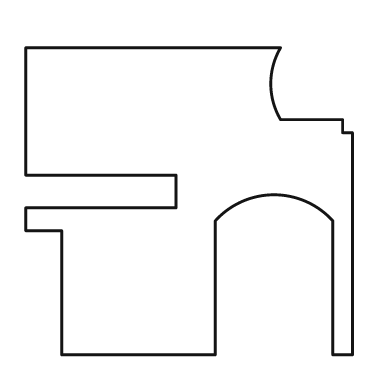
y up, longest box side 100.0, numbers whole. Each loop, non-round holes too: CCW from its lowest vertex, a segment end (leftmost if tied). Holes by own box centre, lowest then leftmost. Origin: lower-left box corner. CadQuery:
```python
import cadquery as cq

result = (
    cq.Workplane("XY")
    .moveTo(11.0, 0.0)
    .lineTo(58.0, 0.0)
    .lineTo(58.0, 41.0)
    .threePointArc((76.0, 49.0), (94.0, 41.0))
    .lineTo(94.0, 0.0)
    .lineTo(100.0, 0.0)
    .lineTo(100.0, 68.0)
    .lineTo(97.0, 68.0)
    .lineTo(97.0, 72.0)
    .lineTo(78.0, 72.0)
    .threePointArc((75.0, 83.0), (78.0, 94.0))
    .lineTo(0.0, 94.0)
    .lineTo(0.0, 55.0)
    .lineTo(46.0, 55.0)
    .lineTo(46.0, 45.0)
    .lineTo(0.0, 45.0)
    .lineTo(0.0, 38.0)
    .lineTo(11.0, 38.0)
    .close()
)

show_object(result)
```